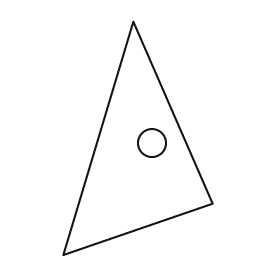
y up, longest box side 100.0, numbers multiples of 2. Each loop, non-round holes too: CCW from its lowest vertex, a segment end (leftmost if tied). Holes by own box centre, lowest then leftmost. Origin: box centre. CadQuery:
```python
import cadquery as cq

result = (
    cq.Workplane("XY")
    .moveTo(-32.0, -50.0)
    .lineTo(32.0, -28.0)
    .lineTo(-2.0, 50.0)
    .close()
    .moveTo(6.0, -2.0)
    .circle(6.0)
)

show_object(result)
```